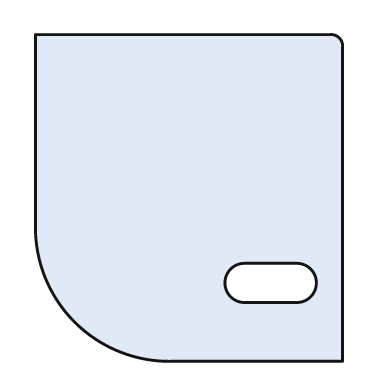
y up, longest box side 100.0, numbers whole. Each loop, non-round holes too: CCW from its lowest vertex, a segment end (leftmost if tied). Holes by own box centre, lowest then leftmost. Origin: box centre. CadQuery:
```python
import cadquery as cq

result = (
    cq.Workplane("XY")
    .moveTo(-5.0, -50.0)
    .lineTo(47.0, -50.0)
    .lineTo(47.0, 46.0)
    .threePointArc((46.0, 49.0), (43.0, 50.0))
    .lineTo(-47.0, 50.0)
    .lineTo(-47.0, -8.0)
    .threePointArc((-35.0, -38.0), (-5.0, -50.0))
    .close()
    .moveTo(17.0, -32.0)
    .lineTo(33.0, -32.0)
    .threePointArc((39.0, -26.0), (33.0, -20.0))
    .lineTo(17.0, -20.0)
    .threePointArc((11.0, -26.0), (17.0, -32.0))
    .close()
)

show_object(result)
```